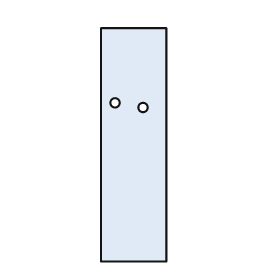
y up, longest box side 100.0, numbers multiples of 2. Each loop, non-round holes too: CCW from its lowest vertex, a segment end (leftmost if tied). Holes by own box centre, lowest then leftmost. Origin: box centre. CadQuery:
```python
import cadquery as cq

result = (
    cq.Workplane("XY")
    .moveTo(-14.0, -50.0)
    .lineTo(14.0, -50.0)
    .lineTo(14.0, 50.0)
    .lineTo(-14.0, 50.0)
    .close()
    .moveTo(4.0, 16.0)
    .circle(2.0)
    .moveTo(-8.0, 18.0)
    .circle(2.0)
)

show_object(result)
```